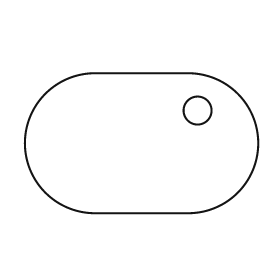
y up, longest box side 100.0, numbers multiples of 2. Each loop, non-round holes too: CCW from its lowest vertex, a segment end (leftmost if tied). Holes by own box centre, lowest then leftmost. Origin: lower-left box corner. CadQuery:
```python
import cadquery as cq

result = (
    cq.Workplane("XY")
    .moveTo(30.0, 0.0)
    .lineTo(70.0, 0.0)
    .threePointArc((100.0, 30.0), (70.0, 60.0))
    .lineTo(30.0, 60.0)
    .threePointArc((0.0, 30.0), (30.0, 0.0))
    .close()
    .moveTo(74.0, 44.0)
    .circle(6.0)
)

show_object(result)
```